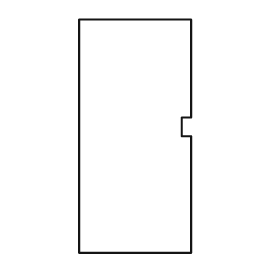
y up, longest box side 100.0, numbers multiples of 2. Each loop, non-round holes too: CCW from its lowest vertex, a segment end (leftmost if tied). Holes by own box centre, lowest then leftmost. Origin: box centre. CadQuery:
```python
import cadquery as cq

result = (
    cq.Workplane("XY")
    .moveTo(-24.0, -50.0)
    .lineTo(24.0, -50.0)
    .lineTo(24.0, 0.0)
    .lineTo(20.0, 0.0)
    .lineTo(20.0, 8.0)
    .lineTo(24.0, 8.0)
    .lineTo(24.0, 50.0)
    .lineTo(-24.0, 50.0)
    .close()
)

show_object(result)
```